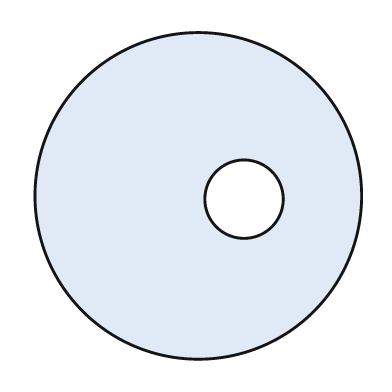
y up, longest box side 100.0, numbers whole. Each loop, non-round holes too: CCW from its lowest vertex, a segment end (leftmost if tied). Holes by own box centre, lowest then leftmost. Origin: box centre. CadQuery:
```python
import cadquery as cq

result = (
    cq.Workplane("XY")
    .moveTo(0.0, 0.0)
    .circle(50.0)
    .moveTo(14.0, -1.0)
    .circle(12.0)
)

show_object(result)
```